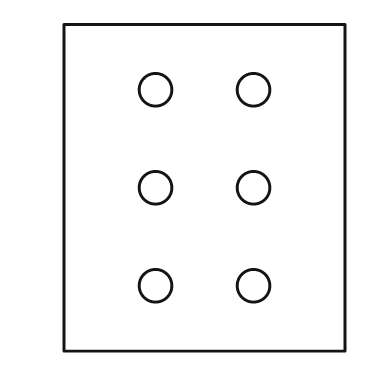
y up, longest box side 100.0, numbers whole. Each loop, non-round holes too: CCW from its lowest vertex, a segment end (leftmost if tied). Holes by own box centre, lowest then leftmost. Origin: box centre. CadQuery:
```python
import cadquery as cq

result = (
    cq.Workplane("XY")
    .moveTo(-43.0, -50.0)
    .lineTo(43.0, -50.0)
    .lineTo(43.0, 50.0)
    .lineTo(-43.0, 50.0)
    .close()
    .moveTo(-15.0, -30.0)
    .circle(5.0)
    .moveTo(15.0, -30.0)
    .circle(5.0)
    .moveTo(-15.0, 0.0)
    .circle(5.0)
    .moveTo(15.0, 0.0)
    .circle(5.0)
    .moveTo(-15.0, 30.0)
    .circle(5.0)
    .moveTo(15.0, 30.0)
    .circle(5.0)
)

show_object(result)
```